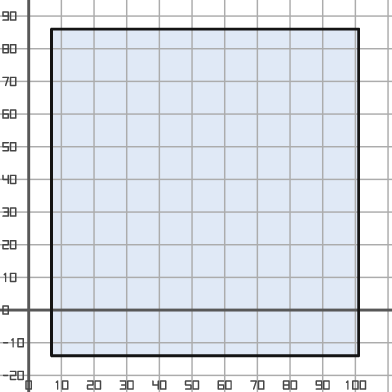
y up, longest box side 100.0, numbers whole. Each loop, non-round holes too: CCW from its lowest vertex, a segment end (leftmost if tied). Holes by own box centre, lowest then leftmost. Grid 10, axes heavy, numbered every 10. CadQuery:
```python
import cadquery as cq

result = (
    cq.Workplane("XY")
    .moveTo(7.0, -14.0)
    .lineTo(101.0, -14.0)
    .lineTo(101.0, 86.0)
    .lineTo(7.0, 86.0)
    .close()
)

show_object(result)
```